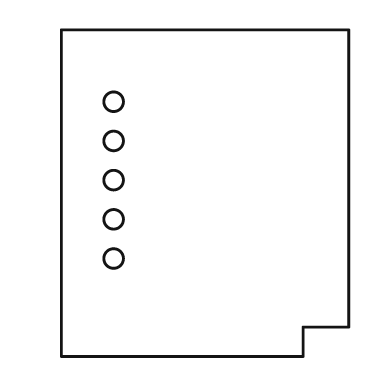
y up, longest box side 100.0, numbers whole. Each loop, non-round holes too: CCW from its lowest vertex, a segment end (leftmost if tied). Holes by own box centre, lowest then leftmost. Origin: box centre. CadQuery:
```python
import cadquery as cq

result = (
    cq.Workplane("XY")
    .moveTo(-44.0, -50.0)
    .lineTo(30.0, -50.0)
    .lineTo(30.0, -41.0)
    .lineTo(44.0, -41.0)
    .lineTo(44.0, 50.0)
    .lineTo(-44.0, 50.0)
    .close()
    .moveTo(-28.0, -20.0)
    .circle(3.0)
    .moveTo(-28.0, -8.0)
    .circle(3.0)
    .moveTo(-28.0, 4.0)
    .circle(3.0)
    .moveTo(-28.0, 16.0)
    .circle(3.0)
    .moveTo(-28.0, 28.0)
    .circle(3.0)
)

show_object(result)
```